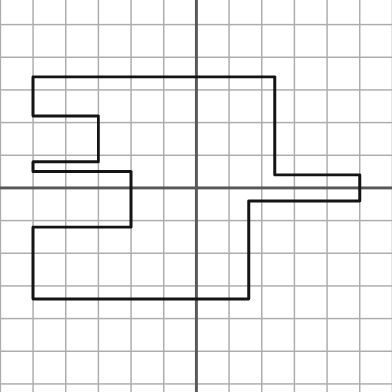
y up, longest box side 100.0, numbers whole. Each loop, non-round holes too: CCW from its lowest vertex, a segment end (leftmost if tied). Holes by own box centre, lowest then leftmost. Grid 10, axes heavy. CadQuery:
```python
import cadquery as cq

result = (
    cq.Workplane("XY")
    .moveTo(-50.0, -34.0)
    .lineTo(16.0, -34.0)
    .lineTo(16.0, -4.0)
    .lineTo(50.0, -4.0)
    .lineTo(50.0, 4.0)
    .lineTo(24.0, 4.0)
    .lineTo(24.0, 34.0)
    .lineTo(-50.0, 34.0)
    .lineTo(-50.0, 22.0)
    .lineTo(-30.0, 22.0)
    .lineTo(-30.0, 8.0)
    .lineTo(-50.0, 8.0)
    .lineTo(-50.0, 5.0)
    .lineTo(-20.0, 5.0)
    .lineTo(-20.0, -12.0)
    .lineTo(-50.0, -12.0)
    .close()
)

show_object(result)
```